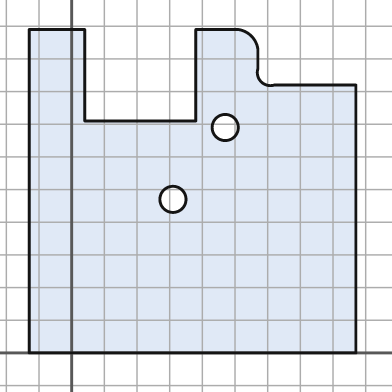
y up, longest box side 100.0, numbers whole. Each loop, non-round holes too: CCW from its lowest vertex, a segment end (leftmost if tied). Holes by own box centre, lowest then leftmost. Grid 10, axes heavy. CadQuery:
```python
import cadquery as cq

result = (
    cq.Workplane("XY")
    .moveTo(-13.0, 0.0)
    .lineTo(87.0, 0.0)
    .lineTo(87.0, 82.0)
    .lineTo(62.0, 82.0)
    .threePointArc((58.0, 83.0), (57.0, 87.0))
    .lineTo(57.0, 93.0)
    .threePointArc((55.0, 97.0), (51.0, 99.0))
    .lineTo(38.0, 99.0)
    .lineTo(38.0, 71.0)
    .lineTo(4.0, 71.0)
    .lineTo(4.0, 99.0)
    .lineTo(-13.0, 99.0)
    .close()
    .moveTo(31.0, 47.0)
    .circle(4.0)
    .moveTo(47.0, 69.0)
    .circle(4.0)
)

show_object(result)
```